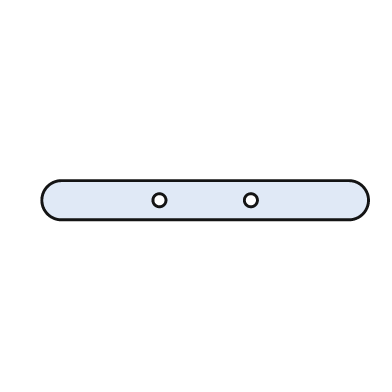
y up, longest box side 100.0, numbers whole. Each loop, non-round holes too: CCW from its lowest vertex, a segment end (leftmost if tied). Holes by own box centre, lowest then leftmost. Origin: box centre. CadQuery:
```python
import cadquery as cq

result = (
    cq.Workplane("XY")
    .moveTo(-44.0, -6.0)
    .lineTo(44.0, -6.0)
    .threePointArc((50.0, 0.0), (44.0, 6.0))
    .lineTo(-44.0, 6.0)
    .threePointArc((-50.0, 0.0), (-44.0, -6.0))
    .close()
    .moveTo(-14.0, 0.0)
    .circle(2.0)
    .moveTo(14.0, 0.0)
    .circle(2.0)
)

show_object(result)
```